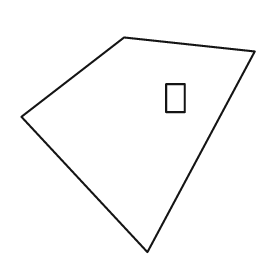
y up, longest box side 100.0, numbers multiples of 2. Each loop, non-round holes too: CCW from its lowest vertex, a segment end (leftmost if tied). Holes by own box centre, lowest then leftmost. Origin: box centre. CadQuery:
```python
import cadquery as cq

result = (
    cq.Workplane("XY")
    .moveTo(4.0, -46.0)
    .lineTo(50.0, 40.0)
    .lineTo(-6.0, 46.0)
    .lineTo(-50.0, 12.0)
    .close()
    .moveTo(12.0, 14.0)
    .lineTo(20.0, 14.0)
    .lineTo(20.0, 26.0)
    .lineTo(12.0, 26.0)
    .close()
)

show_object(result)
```